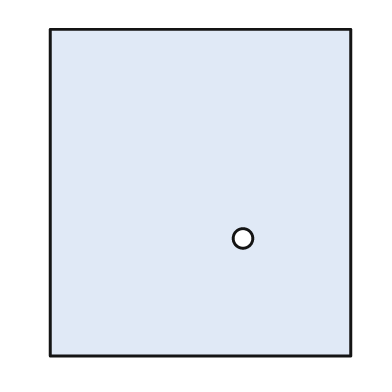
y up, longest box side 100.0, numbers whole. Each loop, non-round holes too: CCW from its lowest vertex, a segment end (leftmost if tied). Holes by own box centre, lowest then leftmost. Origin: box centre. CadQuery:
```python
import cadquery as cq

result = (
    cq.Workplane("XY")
    .moveTo(-46.0, -50.0)
    .lineTo(46.0, -50.0)
    .lineTo(46.0, 50.0)
    .lineTo(-46.0, 50.0)
    .close()
    .moveTo(13.0, -14.0)
    .circle(3.0)
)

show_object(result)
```